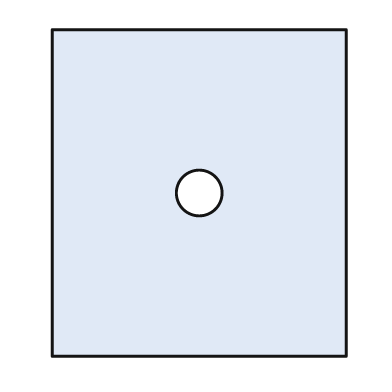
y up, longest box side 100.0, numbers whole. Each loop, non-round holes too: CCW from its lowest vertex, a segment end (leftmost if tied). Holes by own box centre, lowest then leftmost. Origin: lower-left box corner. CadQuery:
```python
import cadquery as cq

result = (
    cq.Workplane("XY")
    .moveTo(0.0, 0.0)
    .lineTo(90.0, 0.0)
    .lineTo(90.0, 100.0)
    .lineTo(0.0, 100.0)
    .close()
    .moveTo(45.0, 50.0)
    .circle(7.0)
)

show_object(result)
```